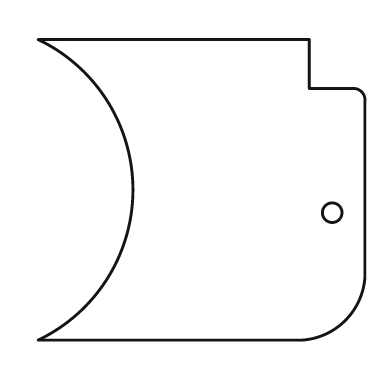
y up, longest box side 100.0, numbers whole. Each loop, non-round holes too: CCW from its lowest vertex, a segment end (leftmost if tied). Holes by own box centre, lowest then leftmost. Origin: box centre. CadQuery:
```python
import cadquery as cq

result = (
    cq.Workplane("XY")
    .moveTo(-50.0, -46.0)
    .lineTo(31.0, -46.0)
    .threePointArc((44.0, -40.0), (50.0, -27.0))
    .lineTo(50.0, 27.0)
    .threePointArc((49.0, 30.0), (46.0, 31.0))
    .lineTo(33.0, 31.0)
    .lineTo(33.0, 46.0)
    .lineTo(-50.0, 46.0)
    .threePointArc((-21.0, 0.0), (-50.0, -46.0))
    .close()
    .moveTo(40.0, -7.0)
    .circle(3.0)
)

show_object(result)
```